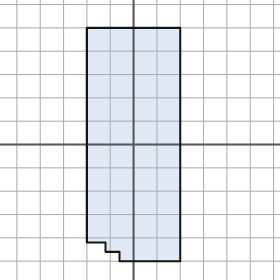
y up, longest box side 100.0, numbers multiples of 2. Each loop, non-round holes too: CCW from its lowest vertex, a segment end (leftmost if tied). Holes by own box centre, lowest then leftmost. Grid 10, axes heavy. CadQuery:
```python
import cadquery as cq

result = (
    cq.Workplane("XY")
    .moveTo(-6.0, -50.0)
    .lineTo(20.0, -50.0)
    .lineTo(20.0, 50.0)
    .lineTo(-20.0, 50.0)
    .lineTo(-20.0, -42.0)
    .lineTo(-12.0, -42.0)
    .lineTo(-12.0, -46.0)
    .lineTo(-6.0, -46.0)
    .close()
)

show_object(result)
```